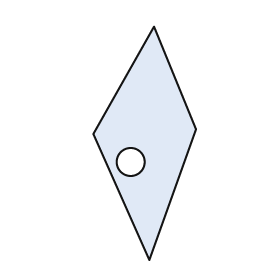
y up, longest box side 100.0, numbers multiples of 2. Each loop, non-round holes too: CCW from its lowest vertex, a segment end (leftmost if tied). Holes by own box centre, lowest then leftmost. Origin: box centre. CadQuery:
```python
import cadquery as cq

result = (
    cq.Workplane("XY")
    .moveTo(2.0, -50.0)
    .lineTo(22.0, 6.0)
    .lineTo(4.0, 50.0)
    .lineTo(-22.0, 4.0)
    .close()
    .moveTo(-6.0, -8.0)
    .circle(6.0)
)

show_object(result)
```